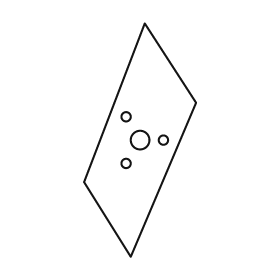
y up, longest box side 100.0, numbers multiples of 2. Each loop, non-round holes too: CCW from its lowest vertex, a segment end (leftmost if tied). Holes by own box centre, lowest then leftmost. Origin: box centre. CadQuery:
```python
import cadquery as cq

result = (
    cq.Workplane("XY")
    .moveTo(-4.0, -50.0)
    .lineTo(24.0, 16.0)
    .lineTo(2.0, 50.0)
    .lineTo(-24.0, -18.0)
    .close()
    .moveTo(-6.0, -10.0)
    .circle(2.0)
    .moveTo(0.0, 0.0)
    .circle(4.0)
    .moveTo(10.0, 0.0)
    .circle(2.0)
    .moveTo(-6.0, 10.0)
    .circle(2.0)
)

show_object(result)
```